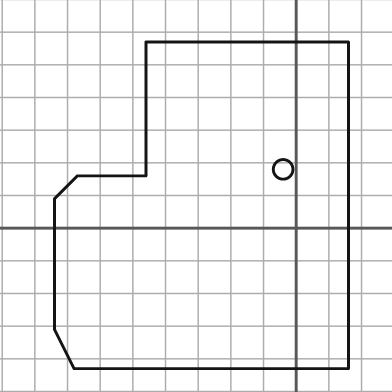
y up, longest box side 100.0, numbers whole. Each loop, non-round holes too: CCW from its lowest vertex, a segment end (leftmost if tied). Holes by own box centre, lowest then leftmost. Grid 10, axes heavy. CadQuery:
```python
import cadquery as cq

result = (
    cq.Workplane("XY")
    .moveTo(-68.0, -43.0)
    .lineTo(16.0, -43.0)
    .lineTo(16.0, 57.0)
    .lineTo(-46.0, 57.0)
    .lineTo(-46.0, 16.0)
    .lineTo(-67.0, 16.0)
    .lineTo(-74.0, 9.0)
    .lineTo(-74.0, -31.0)
    .close()
    .moveTo(-4.0, 18.0)
    .circle(3.0)
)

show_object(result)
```